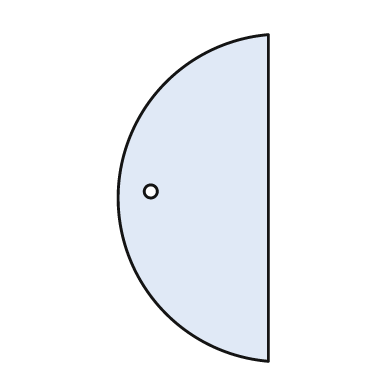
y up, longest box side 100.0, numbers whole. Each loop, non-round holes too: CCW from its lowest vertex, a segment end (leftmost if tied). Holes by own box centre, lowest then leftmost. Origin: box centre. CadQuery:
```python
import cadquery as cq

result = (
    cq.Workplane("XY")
    .moveTo(23.0, -50.0)
    .lineTo(23.0, 50.0)
    .threePointArc((-23.0, 0.0), (23.0, -50.0))
    .close()
    .moveTo(-13.0, 2.0)
    .circle(2.0)
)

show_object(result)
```